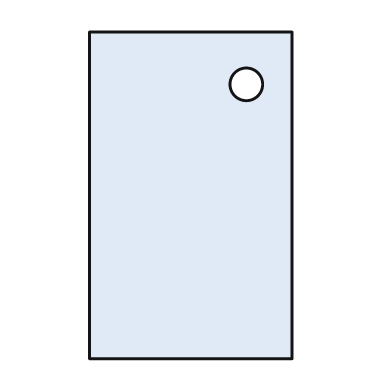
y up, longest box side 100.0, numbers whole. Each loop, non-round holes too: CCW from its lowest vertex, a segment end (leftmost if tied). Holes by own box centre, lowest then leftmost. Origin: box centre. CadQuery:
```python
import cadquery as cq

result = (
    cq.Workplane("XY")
    .moveTo(-31.0, -50.0)
    .lineTo(31.0, -50.0)
    .lineTo(31.0, 50.0)
    .lineTo(-31.0, 50.0)
    .close()
    .moveTo(17.0, 34.0)
    .circle(5.0)
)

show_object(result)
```